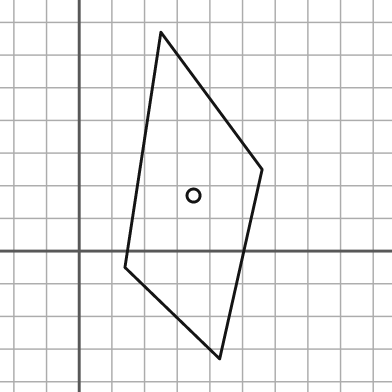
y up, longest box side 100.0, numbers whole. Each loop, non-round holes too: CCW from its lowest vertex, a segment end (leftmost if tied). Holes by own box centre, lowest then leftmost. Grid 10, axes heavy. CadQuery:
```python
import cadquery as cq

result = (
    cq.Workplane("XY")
    .moveTo(43.0, -33.0)
    .lineTo(56.0, 25.0)
    .lineTo(25.0, 67.0)
    .lineTo(14.0, -5.0)
    .close()
    .moveTo(35.0, 17.0)
    .circle(2.0)
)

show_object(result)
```